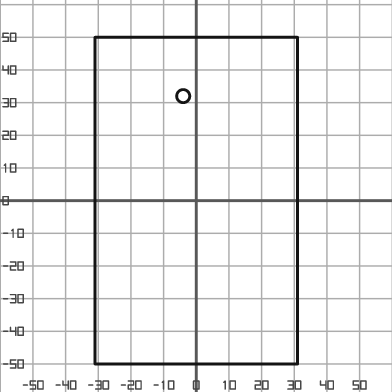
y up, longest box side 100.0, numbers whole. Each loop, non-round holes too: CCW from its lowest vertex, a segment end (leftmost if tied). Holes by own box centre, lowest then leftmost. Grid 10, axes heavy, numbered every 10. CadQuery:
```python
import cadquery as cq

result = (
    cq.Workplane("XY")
    .moveTo(-31.0, -50.0)
    .lineTo(31.0, -50.0)
    .lineTo(31.0, 50.0)
    .lineTo(-31.0, 50.0)
    .close()
    .moveTo(-4.0, 32.0)
    .circle(2.0)
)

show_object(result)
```